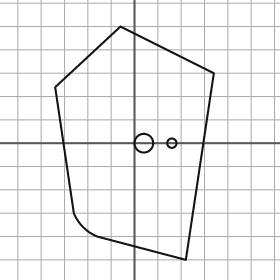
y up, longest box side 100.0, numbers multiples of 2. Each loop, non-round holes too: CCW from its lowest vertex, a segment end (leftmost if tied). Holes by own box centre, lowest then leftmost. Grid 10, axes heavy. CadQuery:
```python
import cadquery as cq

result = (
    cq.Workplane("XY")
    .moveTo(22.0, -50.0)
    .lineTo(34.0, 30.0)
    .lineTo(-6.0, 50.0)
    .lineTo(-34.0, 24.0)
    .lineTo(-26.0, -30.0)
    .threePointArc((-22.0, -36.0), (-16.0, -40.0))
    .close()
    .moveTo(4.0, 0.0)
    .circle(4.0)
    .moveTo(16.0, 0.0)
    .circle(2.0)
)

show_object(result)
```